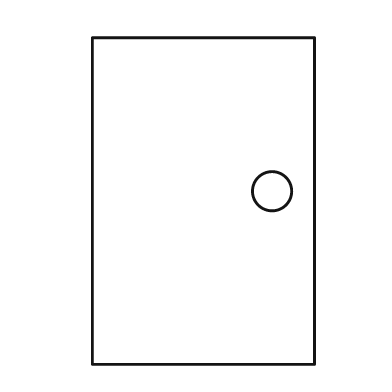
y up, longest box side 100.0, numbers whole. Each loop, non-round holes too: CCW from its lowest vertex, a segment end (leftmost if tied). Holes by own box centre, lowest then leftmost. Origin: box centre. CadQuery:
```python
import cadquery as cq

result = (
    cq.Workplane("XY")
    .moveTo(-34.0, -50.0)
    .lineTo(34.0, -50.0)
    .lineTo(34.0, 50.0)
    .lineTo(-34.0, 50.0)
    .close()
    .moveTo(21.0, 3.0)
    .circle(6.0)
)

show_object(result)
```